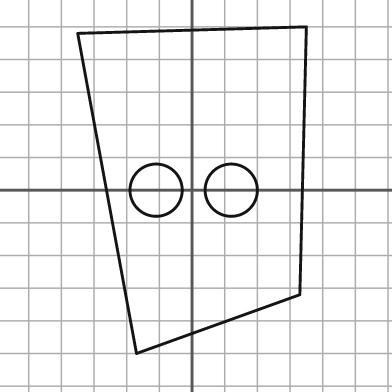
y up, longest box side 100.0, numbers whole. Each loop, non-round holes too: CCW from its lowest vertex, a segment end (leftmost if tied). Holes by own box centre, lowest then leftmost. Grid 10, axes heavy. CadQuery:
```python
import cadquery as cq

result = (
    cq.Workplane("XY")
    .moveTo(-17.0, -50.0)
    .lineTo(33.0, -32.0)
    .lineTo(35.0, 50.0)
    .lineTo(-35.0, 48.0)
    .close()
    .moveTo(-11.0, 0.0)
    .circle(8.0)
    .moveTo(12.0, 0.0)
    .circle(8.0)
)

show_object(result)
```